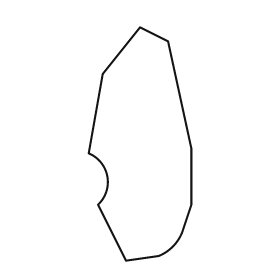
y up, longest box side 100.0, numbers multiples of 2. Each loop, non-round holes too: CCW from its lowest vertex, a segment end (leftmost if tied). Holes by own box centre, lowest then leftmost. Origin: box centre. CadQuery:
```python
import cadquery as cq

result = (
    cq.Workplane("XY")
    .moveTo(-6.0, -50.0)
    .lineTo(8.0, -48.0)
    .threePointArc((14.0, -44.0), (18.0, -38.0))
    .lineTo(22.0, -26.0)
    .lineTo(22.0, -2.0)
    .lineTo(12.0, 44.0)
    .lineTo(0.0, 50.0)
    .lineTo(-16.0, 30.0)
    .lineTo(-22.0, -4.0)
    .threePointArc((-14.0, -14.0), (-18.0, -26.0))
    .close()
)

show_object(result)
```